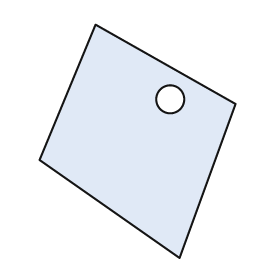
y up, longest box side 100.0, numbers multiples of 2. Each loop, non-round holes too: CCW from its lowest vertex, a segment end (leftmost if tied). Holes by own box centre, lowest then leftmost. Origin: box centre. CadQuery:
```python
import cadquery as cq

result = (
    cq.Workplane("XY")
    .moveTo(18.0, -50.0)
    .lineTo(42.0, 16.0)
    .lineTo(-18.0, 50.0)
    .lineTo(-42.0, -8.0)
    .close()
    .moveTo(14.0, 18.0)
    .circle(6.0)
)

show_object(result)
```